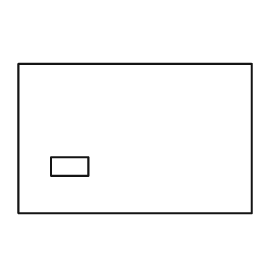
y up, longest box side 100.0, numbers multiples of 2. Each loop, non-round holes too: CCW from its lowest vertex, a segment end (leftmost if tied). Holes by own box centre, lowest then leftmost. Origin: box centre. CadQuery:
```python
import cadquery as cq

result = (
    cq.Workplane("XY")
    .moveTo(-50.0, -32.0)
    .lineTo(50.0, -32.0)
    .lineTo(50.0, 32.0)
    .lineTo(-50.0, 32.0)
    .close()
    .moveTo(-36.0, -16.0)
    .lineTo(-20.0, -16.0)
    .lineTo(-20.0, -8.0)
    .lineTo(-36.0, -8.0)
    .close()
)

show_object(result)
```